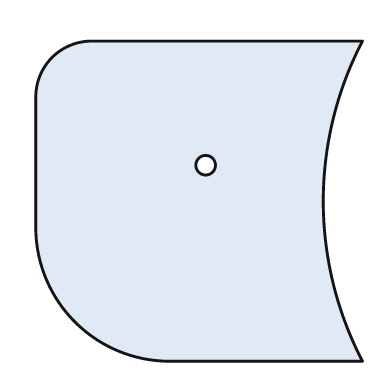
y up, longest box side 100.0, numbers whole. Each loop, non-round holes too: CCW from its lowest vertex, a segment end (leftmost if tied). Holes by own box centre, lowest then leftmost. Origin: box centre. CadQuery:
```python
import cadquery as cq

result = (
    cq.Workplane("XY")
    .moveTo(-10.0, -49.0)
    .lineTo(50.0, -49.0)
    .threePointArc((38.0, 0.0), (50.0, 49.0))
    .lineTo(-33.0, 49.0)
    .threePointArc((-45.0, 44.0), (-50.0, 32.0))
    .lineTo(-50.0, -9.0)
    .threePointArc((-38.0, -37.0), (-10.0, -49.0))
    .close()
    .moveTo(2.0, 11.0)
    .circle(3.0)
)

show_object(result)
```